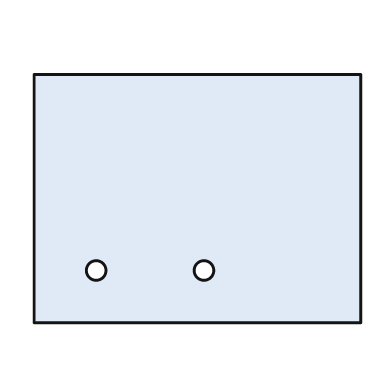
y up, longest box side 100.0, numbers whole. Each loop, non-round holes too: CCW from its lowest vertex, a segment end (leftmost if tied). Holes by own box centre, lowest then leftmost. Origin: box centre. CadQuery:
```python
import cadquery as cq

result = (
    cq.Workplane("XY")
    .moveTo(-50.0, -38.0)
    .lineTo(50.0, -38.0)
    .lineTo(50.0, 38.0)
    .lineTo(-50.0, 38.0)
    .close()
    .moveTo(-31.0, -22.0)
    .circle(3.0)
    .moveTo(2.0, -22.0)
    .circle(3.0)
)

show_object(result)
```